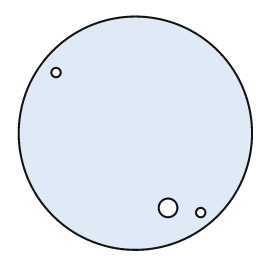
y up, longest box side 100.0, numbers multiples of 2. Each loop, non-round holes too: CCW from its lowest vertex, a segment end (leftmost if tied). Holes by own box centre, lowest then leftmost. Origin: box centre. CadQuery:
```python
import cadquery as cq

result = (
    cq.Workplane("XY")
    .moveTo(0.0, 0.0)
    .circle(50.0)
    .moveTo(28.0, -34.0)
    .circle(2.0)
    .moveTo(14.0, -32.0)
    .circle(4.0)
    .moveTo(-34.0, 26.0)
    .circle(2.0)
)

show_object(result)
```